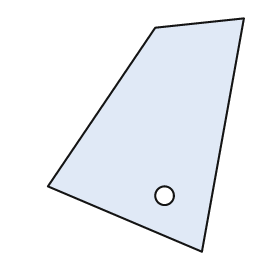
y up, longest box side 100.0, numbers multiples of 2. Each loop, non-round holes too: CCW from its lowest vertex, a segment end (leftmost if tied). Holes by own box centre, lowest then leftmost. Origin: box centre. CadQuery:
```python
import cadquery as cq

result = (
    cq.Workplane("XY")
    .moveTo(24.0, -50.0)
    .lineTo(42.0, 50.0)
    .lineTo(4.0, 46.0)
    .lineTo(-42.0, -22.0)
    .close()
    .moveTo(8.0, -26.0)
    .circle(4.0)
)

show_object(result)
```